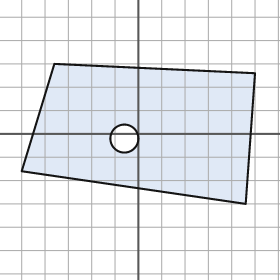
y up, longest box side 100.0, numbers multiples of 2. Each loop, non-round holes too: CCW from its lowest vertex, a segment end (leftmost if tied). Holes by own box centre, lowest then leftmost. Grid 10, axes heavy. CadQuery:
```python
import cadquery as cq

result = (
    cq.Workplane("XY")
    .moveTo(46.0, -30.0)
    .lineTo(50.0, 26.0)
    .lineTo(-36.0, 30.0)
    .lineTo(-50.0, -16.0)
    .close()
    .moveTo(-6.0, -2.0)
    .circle(6.0)
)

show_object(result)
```